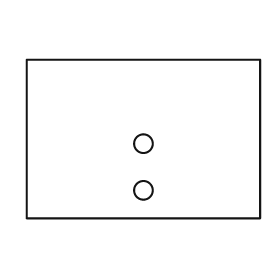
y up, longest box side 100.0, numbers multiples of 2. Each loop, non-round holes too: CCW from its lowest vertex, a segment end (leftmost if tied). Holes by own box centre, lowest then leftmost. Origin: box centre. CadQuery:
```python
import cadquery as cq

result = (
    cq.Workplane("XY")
    .moveTo(-50.0, -34.0)
    .lineTo(50.0, -34.0)
    .lineTo(50.0, 34.0)
    .lineTo(-50.0, 34.0)
    .close()
    .moveTo(0.0, -22.0)
    .circle(4.0)
    .moveTo(0.0, -2.0)
    .circle(4.0)
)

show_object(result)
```